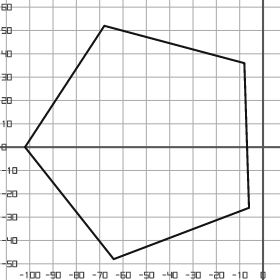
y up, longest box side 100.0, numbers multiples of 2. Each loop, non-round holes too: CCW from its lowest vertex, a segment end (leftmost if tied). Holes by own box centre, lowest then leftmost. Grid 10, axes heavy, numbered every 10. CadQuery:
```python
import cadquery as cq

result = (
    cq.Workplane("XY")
    .moveTo(-64.0, -48.0)
    .lineTo(-6.0, -26.0)
    .lineTo(-8.0, 36.0)
    .lineTo(-68.0, 52.0)
    .lineTo(-102.0, 0.0)
    .close()
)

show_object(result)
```